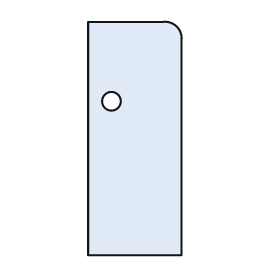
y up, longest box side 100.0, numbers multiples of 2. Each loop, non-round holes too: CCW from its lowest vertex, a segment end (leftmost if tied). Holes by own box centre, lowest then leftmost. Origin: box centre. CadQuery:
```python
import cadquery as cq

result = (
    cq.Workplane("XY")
    .moveTo(-20.0, -50.0)
    .lineTo(20.0, -50.0)
    .lineTo(20.0, 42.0)
    .threePointArc((18.0, 48.0), (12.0, 50.0))
    .lineTo(-20.0, 50.0)
    .close()
    .moveTo(-10.0, 16.0)
    .circle(4.0)
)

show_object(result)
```